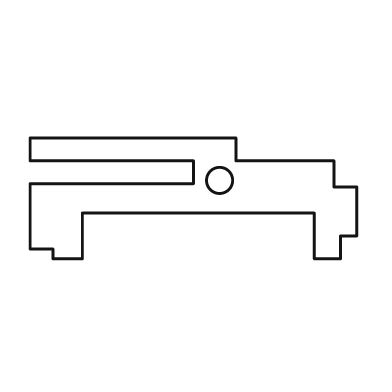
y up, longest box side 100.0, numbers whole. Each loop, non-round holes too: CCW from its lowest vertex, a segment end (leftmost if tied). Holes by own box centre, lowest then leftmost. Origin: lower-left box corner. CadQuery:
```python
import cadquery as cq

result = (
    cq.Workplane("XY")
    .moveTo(7.0, 0.0)
    .lineTo(16.0, 0.0)
    .lineTo(16.0, 14.0)
    .lineTo(87.0, 14.0)
    .lineTo(87.0, 0.0)
    .lineTo(95.0, 0.0)
    .lineTo(95.0, 7.0)
    .lineTo(100.0, 7.0)
    .lineTo(100.0, 22.0)
    .lineTo(93.0, 22.0)
    .lineTo(93.0, 30.0)
    .lineTo(63.0, 30.0)
    .lineTo(63.0, 37.0)
    .lineTo(0.0, 37.0)
    .lineTo(0.0, 30.0)
    .lineTo(50.0, 30.0)
    .lineTo(50.0, 23.0)
    .lineTo(0.0, 23.0)
    .lineTo(0.0, 3.0)
    .lineTo(7.0, 3.0)
    .close()
    .moveTo(58.0, 24.0)
    .circle(4.0)
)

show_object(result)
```